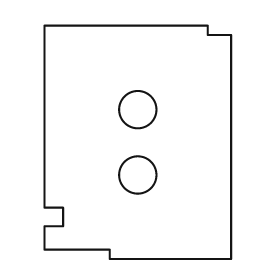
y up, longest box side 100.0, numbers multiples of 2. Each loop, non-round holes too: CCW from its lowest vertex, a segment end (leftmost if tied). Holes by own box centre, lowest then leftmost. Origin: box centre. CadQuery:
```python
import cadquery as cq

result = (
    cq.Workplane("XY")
    .moveTo(-12.0, -50.0)
    .lineTo(40.0, -50.0)
    .lineTo(40.0, 46.0)
    .lineTo(30.0, 46.0)
    .lineTo(30.0, 50.0)
    .lineTo(-40.0, 50.0)
    .lineTo(-40.0, -28.0)
    .lineTo(-32.0, -28.0)
    .lineTo(-32.0, -36.0)
    .lineTo(-40.0, -36.0)
    .lineTo(-40.0, -46.0)
    .lineTo(-12.0, -46.0)
    .close()
    .moveTo(0.0, -14.0)
    .circle(8.0)
    .moveTo(0.0, 14.0)
    .circle(8.0)
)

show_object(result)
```